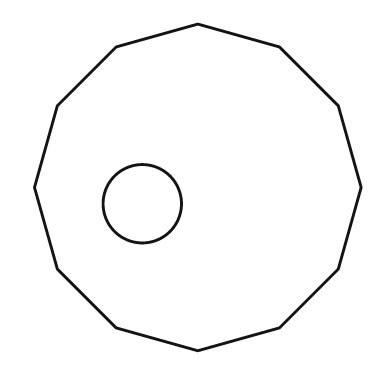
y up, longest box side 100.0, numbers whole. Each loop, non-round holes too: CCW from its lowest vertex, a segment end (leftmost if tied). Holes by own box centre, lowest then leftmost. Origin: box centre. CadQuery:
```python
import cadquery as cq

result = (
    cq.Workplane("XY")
    .moveTo(0.0, -50.0)
    .lineTo(25.0, -43.0)
    .lineTo(43.0, -25.0)
    .lineTo(50.0, 0.0)
    .lineTo(43.0, 25.0)
    .lineTo(25.0, 43.0)
    .lineTo(0.0, 50.0)
    .lineTo(-25.0, 43.0)
    .lineTo(-43.0, 25.0)
    .lineTo(-50.0, 0.0)
    .lineTo(-43.0, -25.0)
    .lineTo(-25.0, -43.0)
    .close()
    .moveTo(-17.0, -5.0)
    .circle(12.0)
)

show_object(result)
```